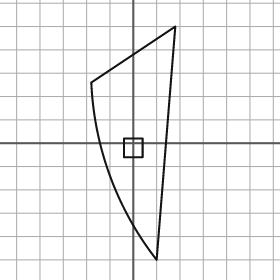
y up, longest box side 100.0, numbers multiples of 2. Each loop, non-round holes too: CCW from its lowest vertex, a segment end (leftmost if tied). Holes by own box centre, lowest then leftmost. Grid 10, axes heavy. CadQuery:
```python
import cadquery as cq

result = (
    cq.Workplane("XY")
    .moveTo(10.0, -50.0)
    .lineTo(18.0, 50.0)
    .lineTo(-18.0, 26.0)
    .threePointArc((-10.0, -14.0), (10.0, -50.0))
    .close()
    .moveTo(-4.0, -6.0)
    .lineTo(4.0, -6.0)
    .lineTo(4.0, 2.0)
    .lineTo(-4.0, 2.0)
    .close()
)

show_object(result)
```